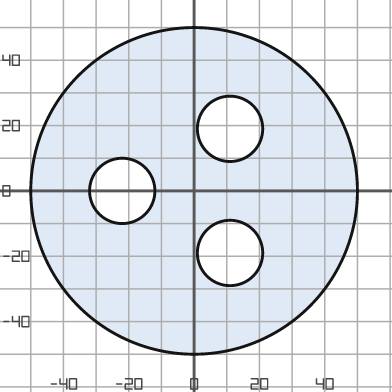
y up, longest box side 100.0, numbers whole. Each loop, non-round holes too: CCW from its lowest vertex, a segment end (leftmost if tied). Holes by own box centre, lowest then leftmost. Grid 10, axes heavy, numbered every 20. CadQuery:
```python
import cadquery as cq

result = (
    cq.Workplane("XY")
    .moveTo(0.0, 0.0)
    .circle(50.0)
    .moveTo(11.0, -19.0)
    .circle(10.0)
    .moveTo(-22.0, 0.0)
    .circle(10.0)
    .moveTo(11.0, 19.0)
    .circle(10.0)
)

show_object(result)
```